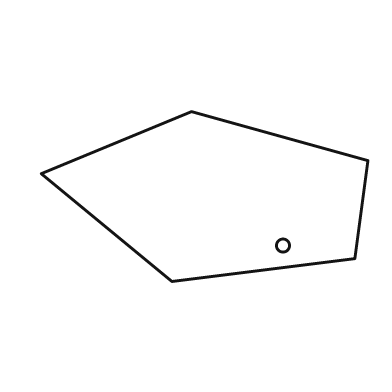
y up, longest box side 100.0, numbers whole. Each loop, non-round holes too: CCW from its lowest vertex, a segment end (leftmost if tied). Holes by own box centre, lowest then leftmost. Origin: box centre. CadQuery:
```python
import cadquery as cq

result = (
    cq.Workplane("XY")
    .moveTo(-10.0, -26.0)
    .lineTo(46.0, -19.0)
    .lineTo(50.0, 11.0)
    .lineTo(-4.0, 26.0)
    .lineTo(-50.0, 7.0)
    .close()
    .moveTo(24.0, -15.0)
    .circle(2.0)
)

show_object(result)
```